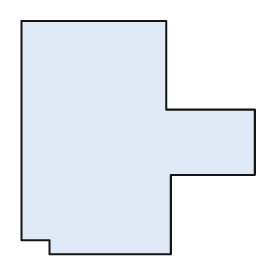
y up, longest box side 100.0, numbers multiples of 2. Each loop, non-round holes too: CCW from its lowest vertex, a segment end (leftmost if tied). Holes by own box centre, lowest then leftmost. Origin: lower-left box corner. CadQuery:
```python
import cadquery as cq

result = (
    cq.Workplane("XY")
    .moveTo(12.0, 0.0)
    .lineTo(64.0, 0.0)
    .lineTo(64.0, 34.0)
    .lineTo(100.0, 34.0)
    .lineTo(100.0, 62.0)
    .lineTo(62.0, 62.0)
    .lineTo(62.0, 100.0)
    .lineTo(0.0, 100.0)
    .lineTo(0.0, 6.0)
    .lineTo(12.0, 6.0)
    .close()
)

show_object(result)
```